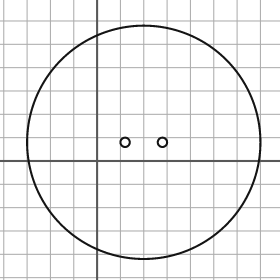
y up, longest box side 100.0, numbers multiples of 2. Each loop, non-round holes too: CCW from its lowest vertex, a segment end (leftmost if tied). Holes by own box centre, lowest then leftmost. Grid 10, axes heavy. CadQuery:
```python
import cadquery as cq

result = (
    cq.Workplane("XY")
    .moveTo(20.0, 8.0)
    .circle(50.0)
    .moveTo(12.0, 8.0)
    .circle(2.0)
    .moveTo(28.0, 8.0)
    .circle(2.0)
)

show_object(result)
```